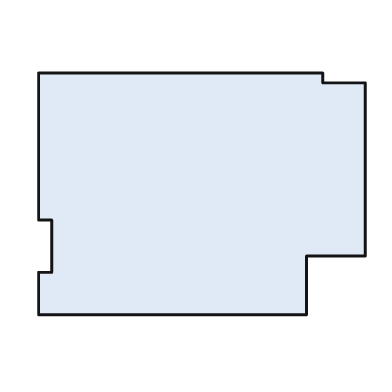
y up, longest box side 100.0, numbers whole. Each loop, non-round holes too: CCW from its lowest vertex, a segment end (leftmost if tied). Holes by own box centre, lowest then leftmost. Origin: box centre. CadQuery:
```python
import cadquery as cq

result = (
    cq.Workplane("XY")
    .moveTo(-50.0, -37.0)
    .lineTo(32.0, -37.0)
    .lineTo(32.0, -19.0)
    .lineTo(50.0, -19.0)
    .lineTo(50.0, 34.0)
    .lineTo(37.0, 34.0)
    .lineTo(37.0, 37.0)
    .lineTo(-50.0, 37.0)
    .lineTo(-50.0, -8.0)
    .lineTo(-46.0, -8.0)
    .lineTo(-46.0, -24.0)
    .lineTo(-50.0, -24.0)
    .close()
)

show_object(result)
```